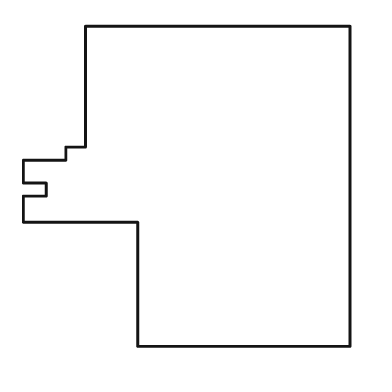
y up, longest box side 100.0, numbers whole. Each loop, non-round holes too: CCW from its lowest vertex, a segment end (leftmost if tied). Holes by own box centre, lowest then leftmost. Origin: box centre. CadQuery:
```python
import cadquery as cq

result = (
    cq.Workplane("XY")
    .moveTo(-15.0, -49.0)
    .lineTo(50.0, -49.0)
    .lineTo(50.0, 49.0)
    .lineTo(-31.0, 49.0)
    .lineTo(-31.0, 12.0)
    .lineTo(-37.0, 12.0)
    .lineTo(-37.0, 8.0)
    .lineTo(-50.0, 8.0)
    .lineTo(-50.0, 1.0)
    .lineTo(-43.0, 1.0)
    .lineTo(-43.0, -3.0)
    .lineTo(-50.0, -3.0)
    .lineTo(-50.0, -11.0)
    .lineTo(-15.0, -11.0)
    .close()
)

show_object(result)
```